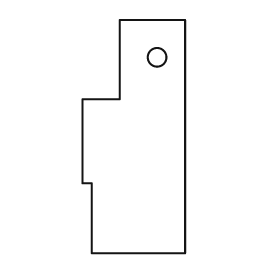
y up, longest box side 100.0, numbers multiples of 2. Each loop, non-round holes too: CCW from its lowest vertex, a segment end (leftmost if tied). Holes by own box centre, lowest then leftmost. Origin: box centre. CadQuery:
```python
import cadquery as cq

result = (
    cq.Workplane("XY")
    .moveTo(-18.0, -50.0)
    .lineTo(22.0, -50.0)
    .lineTo(22.0, 50.0)
    .lineTo(-6.0, 50.0)
    .lineTo(-6.0, 16.0)
    .lineTo(-22.0, 16.0)
    .lineTo(-22.0, -20.0)
    .lineTo(-18.0, -20.0)
    .close()
    .moveTo(10.0, 34.0)
    .circle(4.0)
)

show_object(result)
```